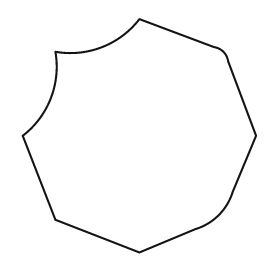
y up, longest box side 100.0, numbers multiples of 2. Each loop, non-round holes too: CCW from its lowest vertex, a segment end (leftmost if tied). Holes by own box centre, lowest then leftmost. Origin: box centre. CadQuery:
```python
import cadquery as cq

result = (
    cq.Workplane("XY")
    .moveTo(0.0, -50.0)
    .lineTo(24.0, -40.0)
    .threePointArc((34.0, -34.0), (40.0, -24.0))
    .lineTo(50.0, 0.0)
    .lineTo(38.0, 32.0)
    .threePointArc((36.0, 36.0), (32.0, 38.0))
    .lineTo(0.0, 50.0)
    .threePointArc((-16.0, 38.0), (-36.0, 36.0))
    .threePointArc((-38.0, 16.0), (-50.0, 0.0))
    .lineTo(-36.0, -36.0)
    .close()
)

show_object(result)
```